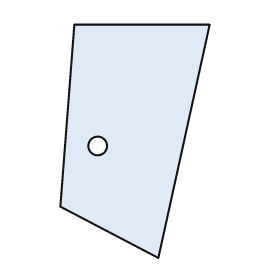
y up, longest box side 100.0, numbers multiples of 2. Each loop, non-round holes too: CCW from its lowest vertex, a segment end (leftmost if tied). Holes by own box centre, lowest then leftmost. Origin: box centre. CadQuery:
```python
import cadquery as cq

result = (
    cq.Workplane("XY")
    .moveTo(10.0, -50.0)
    .lineTo(32.0, 50.0)
    .lineTo(-26.0, 50.0)
    .lineTo(-32.0, -28.0)
    .close()
    .moveTo(-16.0, -2.0)
    .circle(4.0)
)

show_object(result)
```